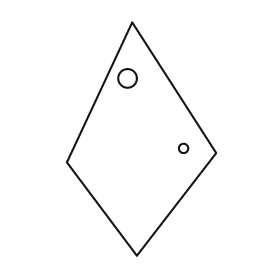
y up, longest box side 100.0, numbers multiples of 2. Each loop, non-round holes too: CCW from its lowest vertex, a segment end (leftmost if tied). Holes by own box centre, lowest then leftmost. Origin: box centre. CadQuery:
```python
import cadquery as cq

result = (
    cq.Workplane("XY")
    .moveTo(-2.0, -50.0)
    .lineTo(32.0, -6.0)
    .lineTo(-4.0, 50.0)
    .lineTo(-32.0, -10.0)
    .close()
    .moveTo(18.0, -4.0)
    .circle(2.0)
    .moveTo(-6.0, 26.0)
    .circle(4.0)
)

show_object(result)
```